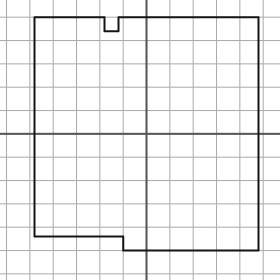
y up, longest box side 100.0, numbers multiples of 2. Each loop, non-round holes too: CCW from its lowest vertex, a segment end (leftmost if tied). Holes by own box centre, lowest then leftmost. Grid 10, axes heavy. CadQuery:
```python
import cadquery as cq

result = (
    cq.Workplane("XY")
    .moveTo(-10.0, -50.0)
    .lineTo(48.0, -50.0)
    .lineTo(48.0, 50.0)
    .lineTo(-12.0, 50.0)
    .lineTo(-12.0, 44.0)
    .lineTo(-18.0, 44.0)
    .lineTo(-18.0, 50.0)
    .lineTo(-48.0, 50.0)
    .lineTo(-48.0, -44.0)
    .lineTo(-10.0, -44.0)
    .close()
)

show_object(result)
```